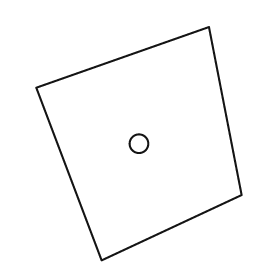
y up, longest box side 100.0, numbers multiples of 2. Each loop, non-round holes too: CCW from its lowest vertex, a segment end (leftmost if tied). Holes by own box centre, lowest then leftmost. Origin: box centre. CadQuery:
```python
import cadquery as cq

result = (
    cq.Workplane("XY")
    .moveTo(-16.0, -50.0)
    .lineTo(44.0, -22.0)
    .lineTo(30.0, 50.0)
    .lineTo(-44.0, 24.0)
    .close()
    .moveTo(0.0, 0.0)
    .circle(4.0)
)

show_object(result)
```